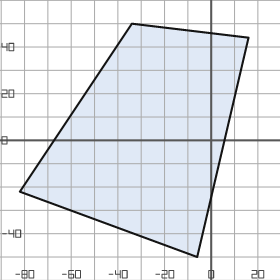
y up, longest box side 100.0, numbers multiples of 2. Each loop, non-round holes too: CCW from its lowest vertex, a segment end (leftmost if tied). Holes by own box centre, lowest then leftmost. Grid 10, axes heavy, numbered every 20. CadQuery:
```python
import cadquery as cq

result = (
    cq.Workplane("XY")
    .moveTo(-6.0, -50.0)
    .lineTo(16.0, 44.0)
    .lineTo(-34.0, 50.0)
    .lineTo(-82.0, -22.0)
    .close()
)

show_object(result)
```